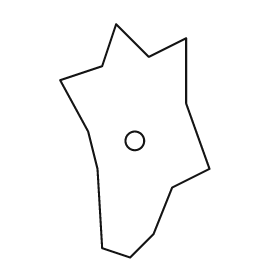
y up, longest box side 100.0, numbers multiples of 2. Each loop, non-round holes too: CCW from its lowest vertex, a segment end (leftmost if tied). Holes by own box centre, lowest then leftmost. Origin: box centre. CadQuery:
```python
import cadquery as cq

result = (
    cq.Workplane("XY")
    .moveTo(-2.0, -50.0)
    .lineTo(8.0, -40.0)
    .lineTo(16.0, -20.0)
    .lineTo(32.0, -12.0)
    .lineTo(22.0, 16.0)
    .lineTo(22.0, 44.0)
    .lineTo(6.0, 36.0)
    .lineTo(-8.0, 50.0)
    .lineTo(-14.0, 32.0)
    .lineTo(-32.0, 26.0)
    .lineTo(-20.0, 4.0)
    .lineTo(-16.0, -12.0)
    .lineTo(-14.0, -46.0)
    .close()
    .moveTo(0.0, 0.0)
    .circle(4.0)
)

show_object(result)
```